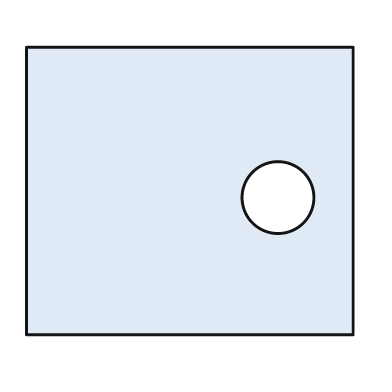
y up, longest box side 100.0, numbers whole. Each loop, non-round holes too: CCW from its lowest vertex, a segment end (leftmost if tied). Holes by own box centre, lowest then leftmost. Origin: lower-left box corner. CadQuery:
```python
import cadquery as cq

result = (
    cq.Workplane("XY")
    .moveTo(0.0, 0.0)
    .lineTo(100.0, 0.0)
    .lineTo(100.0, 88.0)
    .lineTo(0.0, 88.0)
    .close()
    .moveTo(77.0, 42.0)
    .circle(11.0)
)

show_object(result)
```